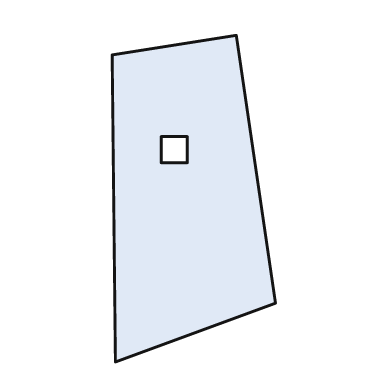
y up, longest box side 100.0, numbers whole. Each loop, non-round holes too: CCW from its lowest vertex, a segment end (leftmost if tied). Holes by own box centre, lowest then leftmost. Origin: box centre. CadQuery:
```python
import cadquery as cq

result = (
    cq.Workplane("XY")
    .moveTo(-24.0, -50.0)
    .lineTo(25.0, -32.0)
    .lineTo(13.0, 50.0)
    .lineTo(-25.0, 44.0)
    .close()
    .moveTo(-10.0, 11.0)
    .lineTo(-2.0, 11.0)
    .lineTo(-2.0, 19.0)
    .lineTo(-10.0, 19.0)
    .close()
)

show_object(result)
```